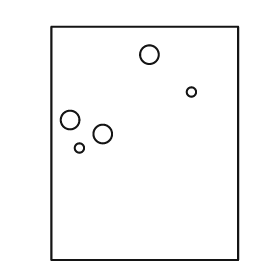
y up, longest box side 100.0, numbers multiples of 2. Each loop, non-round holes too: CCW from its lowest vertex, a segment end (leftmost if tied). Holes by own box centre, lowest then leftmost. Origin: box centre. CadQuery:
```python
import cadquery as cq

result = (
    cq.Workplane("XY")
    .moveTo(-40.0, -50.0)
    .lineTo(40.0, -50.0)
    .lineTo(40.0, 50.0)
    .lineTo(-40.0, 50.0)
    .close()
    .moveTo(-28.0, -2.0)
    .circle(2.0)
    .moveTo(-18.0, 4.0)
    .circle(4.0)
    .moveTo(-32.0, 10.0)
    .circle(4.0)
    .moveTo(20.0, 22.0)
    .circle(2.0)
    .moveTo(2.0, 38.0)
    .circle(4.0)
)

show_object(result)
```